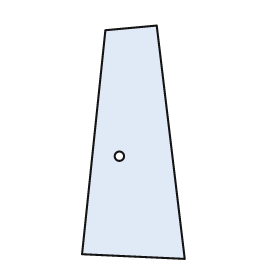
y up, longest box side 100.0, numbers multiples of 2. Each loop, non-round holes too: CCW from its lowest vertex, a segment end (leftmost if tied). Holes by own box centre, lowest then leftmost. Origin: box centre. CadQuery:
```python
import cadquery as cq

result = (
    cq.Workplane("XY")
    .moveTo(22.0, -50.0)
    .lineTo(10.0, 50.0)
    .lineTo(-12.0, 48.0)
    .lineTo(-22.0, -48.0)
    .close()
    .moveTo(-6.0, -6.0)
    .circle(2.0)
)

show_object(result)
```